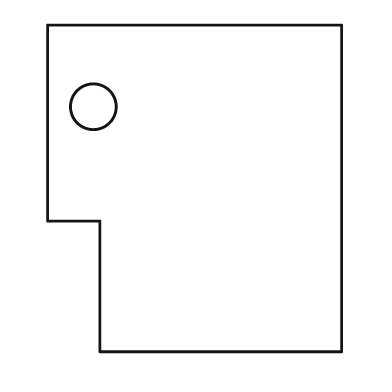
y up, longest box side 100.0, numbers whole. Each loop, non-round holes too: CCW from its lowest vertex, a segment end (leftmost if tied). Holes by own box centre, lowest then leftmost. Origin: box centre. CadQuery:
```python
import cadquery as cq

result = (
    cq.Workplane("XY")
    .moveTo(-29.0, -50.0)
    .lineTo(45.0, -50.0)
    .lineTo(45.0, 50.0)
    .lineTo(-45.0, 50.0)
    .lineTo(-45.0, -10.0)
    .lineTo(-29.0, -10.0)
    .close()
    .moveTo(-31.0, 25.0)
    .circle(7.0)
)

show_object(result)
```